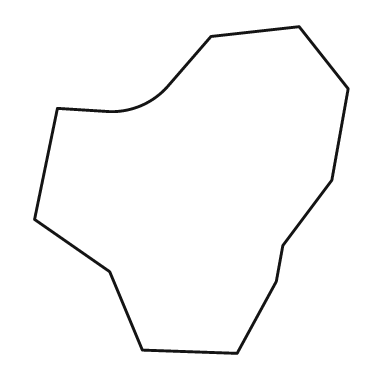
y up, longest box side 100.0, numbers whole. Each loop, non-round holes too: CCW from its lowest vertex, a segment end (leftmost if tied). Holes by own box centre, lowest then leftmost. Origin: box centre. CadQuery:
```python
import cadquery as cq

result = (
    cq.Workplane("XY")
    .moveTo(14.0, -50.0)
    .lineTo(26.0, -28.0)
    .lineTo(28.0, -17.0)
    .lineTo(43.0, 3.0)
    .lineTo(48.0, 31.0)
    .lineTo(33.0, 50.0)
    .lineTo(6.0, 47.0)
    .lineTo(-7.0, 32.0)
    .threePointArc((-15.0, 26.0), (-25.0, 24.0))
    .lineTo(-41.0, 25.0)
    .lineTo(-48.0, -9.0)
    .lineTo(-25.0, -25.0)
    .lineTo(-15.0, -49.0)
    .close()
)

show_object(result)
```